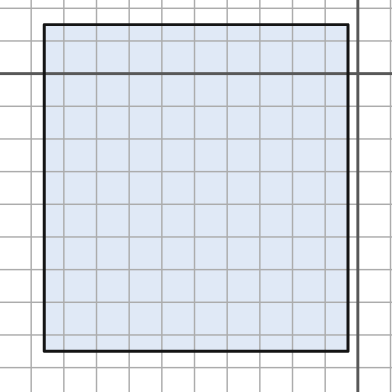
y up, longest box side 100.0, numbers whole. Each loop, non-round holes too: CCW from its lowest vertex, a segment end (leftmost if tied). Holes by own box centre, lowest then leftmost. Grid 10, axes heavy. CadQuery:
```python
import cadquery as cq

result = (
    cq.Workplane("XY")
    .moveTo(-96.0, -85.0)
    .lineTo(-3.0, -85.0)
    .lineTo(-3.0, 15.0)
    .lineTo(-96.0, 15.0)
    .close()
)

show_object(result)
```